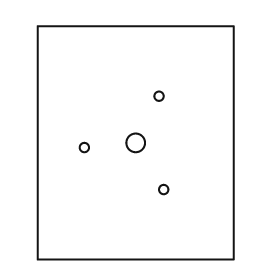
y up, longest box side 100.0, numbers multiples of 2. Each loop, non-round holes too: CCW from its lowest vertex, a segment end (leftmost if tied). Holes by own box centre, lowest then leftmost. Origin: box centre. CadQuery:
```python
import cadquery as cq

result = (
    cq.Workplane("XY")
    .moveTo(-42.0, -50.0)
    .lineTo(42.0, -50.0)
    .lineTo(42.0, 50.0)
    .lineTo(-42.0, 50.0)
    .close()
    .moveTo(12.0, -20.0)
    .circle(2.0)
    .moveTo(-22.0, -2.0)
    .circle(2.0)
    .moveTo(0.0, 0.0)
    .circle(4.0)
    .moveTo(10.0, 20.0)
    .circle(2.0)
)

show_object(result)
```